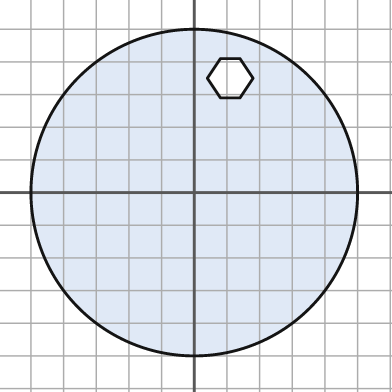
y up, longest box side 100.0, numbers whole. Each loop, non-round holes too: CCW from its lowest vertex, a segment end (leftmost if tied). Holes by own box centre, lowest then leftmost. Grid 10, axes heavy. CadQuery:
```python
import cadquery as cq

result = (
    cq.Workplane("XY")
    .moveTo(0.0, 0.0)
    .circle(50.0)
    .moveTo(8.0, 29.0)
    .lineTo(14.0, 29.0)
    .lineTo(18.0, 35.0)
    .lineTo(14.0, 41.0)
    .lineTo(8.0, 41.0)
    .lineTo(4.0, 35.0)
    .close()
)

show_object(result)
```